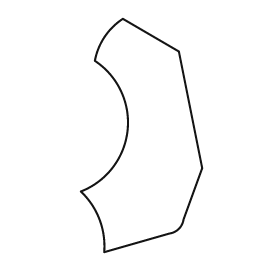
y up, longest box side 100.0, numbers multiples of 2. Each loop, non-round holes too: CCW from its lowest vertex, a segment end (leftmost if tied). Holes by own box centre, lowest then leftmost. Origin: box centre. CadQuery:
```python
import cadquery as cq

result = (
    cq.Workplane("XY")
    .moveTo(-16.0, -50.0)
    .lineTo(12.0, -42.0)
    .threePointArc((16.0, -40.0), (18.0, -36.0))
    .lineTo(26.0, -14.0)
    .lineTo(16.0, 36.0)
    .lineTo(-8.0, 50.0)
    .threePointArc((-16.0, 42.0), (-20.0, 32.0))
    .threePointArc((-6.0, 2.0), (-26.0, -24.0))
    .threePointArc((-18.0, -36.0), (-16.0, -50.0))
    .close()
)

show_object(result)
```